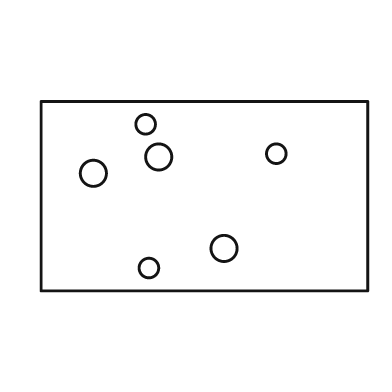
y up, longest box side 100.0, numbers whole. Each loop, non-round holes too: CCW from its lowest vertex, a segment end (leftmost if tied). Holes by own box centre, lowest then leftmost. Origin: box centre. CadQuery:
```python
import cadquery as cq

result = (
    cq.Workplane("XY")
    .moveTo(-50.0, -29.0)
    .lineTo(50.0, -29.0)
    .lineTo(50.0, 29.0)
    .lineTo(-50.0, 29.0)
    .close()
    .moveTo(-17.0, -22.0)
    .circle(3.0)
    .moveTo(6.0, -16.0)
    .circle(4.0)
    .moveTo(-34.0, 7.0)
    .circle(4.0)
    .moveTo(-14.0, 12.0)
    .circle(4.0)
    .moveTo(22.0, 13.0)
    .circle(3.0)
    .moveTo(-18.0, 22.0)
    .circle(3.0)
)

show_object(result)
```